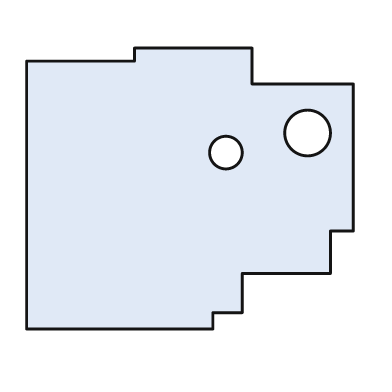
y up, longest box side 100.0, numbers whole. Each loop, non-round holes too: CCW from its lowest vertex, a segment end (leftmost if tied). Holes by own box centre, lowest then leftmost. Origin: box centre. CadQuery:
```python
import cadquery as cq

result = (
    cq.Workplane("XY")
    .moveTo(-50.0, -43.0)
    .lineTo(7.0, -43.0)
    .lineTo(7.0, -38.0)
    .lineTo(16.0, -38.0)
    .lineTo(16.0, -26.0)
    .lineTo(43.0, -26.0)
    .lineTo(43.0, -13.0)
    .lineTo(50.0, -13.0)
    .lineTo(50.0, 32.0)
    .lineTo(19.0, 32.0)
    .lineTo(19.0, 43.0)
    .lineTo(-17.0, 43.0)
    .lineTo(-17.0, 39.0)
    .lineTo(-50.0, 39.0)
    .close()
    .moveTo(11.0, 11.0)
    .circle(5.0)
    .moveTo(36.0, 17.0)
    .circle(7.0)
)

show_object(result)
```